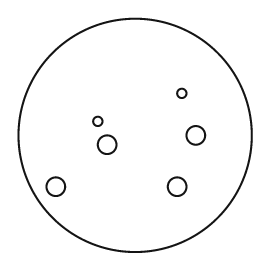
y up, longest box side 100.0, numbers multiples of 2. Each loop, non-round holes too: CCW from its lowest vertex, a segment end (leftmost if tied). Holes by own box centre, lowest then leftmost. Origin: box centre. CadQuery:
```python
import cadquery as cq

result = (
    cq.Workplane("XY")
    .moveTo(0.0, 0.0)
    .circle(50.0)
    .moveTo(-34.0, -22.0)
    .circle(4.0)
    .moveTo(18.0, -22.0)
    .circle(4.0)
    .moveTo(-12.0, -4.0)
    .circle(4.0)
    .moveTo(26.0, 0.0)
    .circle(4.0)
    .moveTo(-16.0, 6.0)
    .circle(2.0)
    .moveTo(20.0, 18.0)
    .circle(2.0)
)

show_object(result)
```